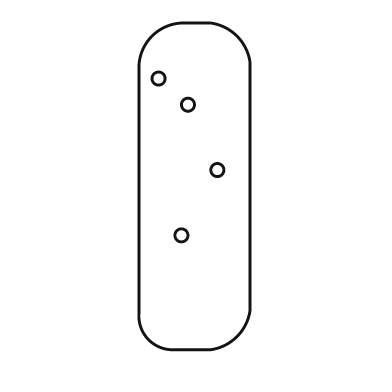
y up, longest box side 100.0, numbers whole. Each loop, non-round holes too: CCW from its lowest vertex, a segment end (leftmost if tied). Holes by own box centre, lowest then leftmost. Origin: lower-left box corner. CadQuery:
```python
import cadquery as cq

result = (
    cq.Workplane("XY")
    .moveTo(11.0, 0.0)
    .lineTo(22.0, 0.0)
    .threePointArc((30.0, 4.0), (34.0, 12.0))
    .lineTo(34.0, 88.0)
    .threePointArc((30.0, 96.0), (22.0, 100.0))
    .lineTo(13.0, 100.0)
    .threePointArc((4.0, 96.0), (0.0, 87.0))
    .lineTo(0.0, 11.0)
    .threePointArc((3.0, 3.0), (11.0, 0.0))
    .close()
    .moveTo(13.0, 35.0)
    .circle(2.0)
    .moveTo(24.0, 55.0)
    .circle(2.0)
    .moveTo(15.0, 75.0)
    .circle(2.0)
    .moveTo(6.0, 83.0)
    .circle(2.0)
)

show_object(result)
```